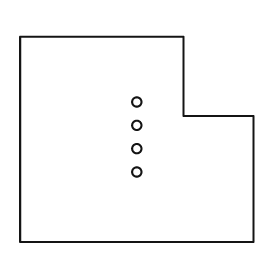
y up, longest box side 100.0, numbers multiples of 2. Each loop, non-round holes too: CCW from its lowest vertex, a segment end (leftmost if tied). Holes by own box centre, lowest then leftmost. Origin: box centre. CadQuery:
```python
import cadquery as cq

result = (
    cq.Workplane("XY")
    .moveTo(-50.0, -44.0)
    .lineTo(50.0, -44.0)
    .lineTo(50.0, 10.0)
    .lineTo(20.0, 10.0)
    .lineTo(20.0, 44.0)
    .lineTo(-50.0, 44.0)
    .close()
    .moveTo(0.0, -14.0)
    .circle(2.0)
    .moveTo(0.0, -4.0)
    .circle(2.0)
    .moveTo(0.0, 6.0)
    .circle(2.0)
    .moveTo(0.0, 16.0)
    .circle(2.0)
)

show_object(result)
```